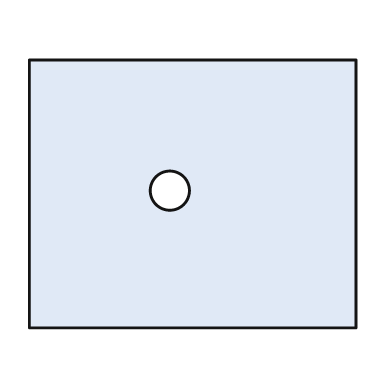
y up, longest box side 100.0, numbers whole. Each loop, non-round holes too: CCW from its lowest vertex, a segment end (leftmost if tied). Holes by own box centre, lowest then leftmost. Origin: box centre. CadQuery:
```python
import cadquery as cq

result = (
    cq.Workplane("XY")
    .moveTo(-50.0, -41.0)
    .lineTo(50.0, -41.0)
    .lineTo(50.0, 41.0)
    .lineTo(-50.0, 41.0)
    .close()
    .moveTo(-7.0, 1.0)
    .circle(6.0)
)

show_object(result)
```